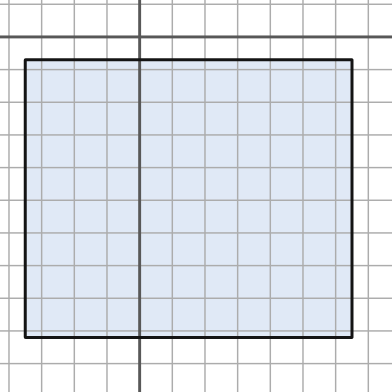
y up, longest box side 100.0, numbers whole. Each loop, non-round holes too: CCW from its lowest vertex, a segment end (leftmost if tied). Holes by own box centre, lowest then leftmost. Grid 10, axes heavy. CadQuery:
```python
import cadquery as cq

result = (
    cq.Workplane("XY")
    .moveTo(-35.0, -92.0)
    .lineTo(65.0, -92.0)
    .lineTo(65.0, -7.0)
    .lineTo(-35.0, -7.0)
    .close()
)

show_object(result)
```